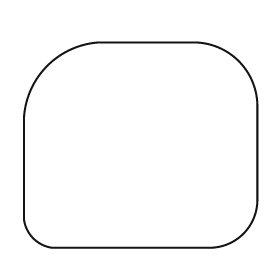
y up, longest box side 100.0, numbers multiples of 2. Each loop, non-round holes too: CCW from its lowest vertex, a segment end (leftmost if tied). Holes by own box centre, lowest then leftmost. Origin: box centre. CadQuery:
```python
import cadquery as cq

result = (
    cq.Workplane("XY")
    .moveTo(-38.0, -44.0)
    .lineTo(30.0, -44.0)
    .threePointArc((44.0, -38.0), (50.0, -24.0))
    .lineTo(50.0, 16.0)
    .threePointArc((42.0, 36.0), (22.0, 44.0))
    .lineTo(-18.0, 44.0)
    .threePointArc((-40.0, 34.0), (-50.0, 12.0))
    .lineTo(-50.0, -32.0)
    .threePointArc((-46.0, -40.0), (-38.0, -44.0))
    .close()
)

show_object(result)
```